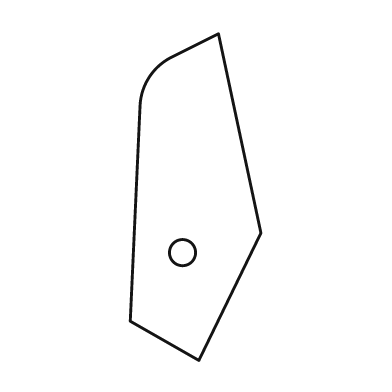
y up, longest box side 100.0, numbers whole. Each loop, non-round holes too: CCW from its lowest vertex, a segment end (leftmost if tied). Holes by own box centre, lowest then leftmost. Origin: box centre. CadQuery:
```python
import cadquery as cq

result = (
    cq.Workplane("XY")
    .moveTo(1.0, -50.0)
    .lineTo(20.0, -11.0)
    .lineTo(7.0, 50.0)
    .lineTo(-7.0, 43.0)
    .threePointArc((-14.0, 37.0), (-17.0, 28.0))
    .lineTo(-20.0, -38.0)
    .close()
    .moveTo(-4.0, -17.0)
    .circle(4.0)
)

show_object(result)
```